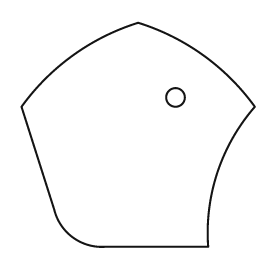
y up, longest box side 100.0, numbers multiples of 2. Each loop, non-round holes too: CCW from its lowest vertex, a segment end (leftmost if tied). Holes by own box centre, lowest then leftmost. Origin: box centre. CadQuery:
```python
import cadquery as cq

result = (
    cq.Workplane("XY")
    .moveTo(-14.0, -48.0)
    .lineTo(30.0, -48.0)
    .threePointArc((34.0, -16.0), (50.0, 12.0))
    .threePointArc((28.0, 34.0), (0.0, 48.0))
    .threePointArc((-28.0, 34.0), (-50.0, 12.0))
    .lineTo(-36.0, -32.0)
    .threePointArc((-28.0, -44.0), (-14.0, -48.0))
    .close()
    .moveTo(16.0, 16.0)
    .circle(4.0)
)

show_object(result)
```